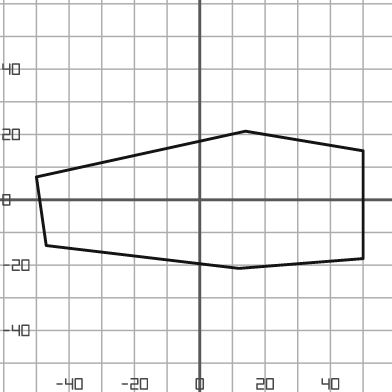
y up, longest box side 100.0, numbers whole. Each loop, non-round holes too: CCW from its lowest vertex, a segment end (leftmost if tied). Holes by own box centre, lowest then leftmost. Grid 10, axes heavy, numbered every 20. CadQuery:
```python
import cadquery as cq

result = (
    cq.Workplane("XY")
    .moveTo(12.0, -21.0)
    .lineTo(50.0, -18.0)
    .lineTo(50.0, 15.0)
    .lineTo(14.0, 21.0)
    .lineTo(-50.0, 7.0)
    .lineTo(-47.0, -14.0)
    .close()
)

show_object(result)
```